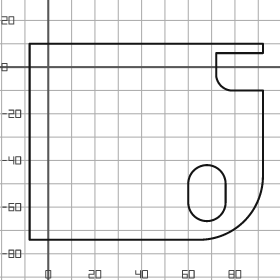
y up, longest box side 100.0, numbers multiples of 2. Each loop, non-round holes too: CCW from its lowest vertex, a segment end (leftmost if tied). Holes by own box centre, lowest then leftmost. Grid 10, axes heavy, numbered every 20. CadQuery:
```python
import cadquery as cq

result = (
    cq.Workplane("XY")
    .moveTo(-8.0, -74.0)
    .lineTo(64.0, -74.0)
    .threePointArc((84.0, -66.0), (92.0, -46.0))
    .lineTo(92.0, -10.0)
    .lineTo(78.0, -10.0)
    .threePointArc((74.0, -8.0), (72.0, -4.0))
    .lineTo(72.0, 6.0)
    .lineTo(92.0, 6.0)
    .lineTo(92.0, 10.0)
    .lineTo(-8.0, 10.0)
    .close()
    .moveTo(60.0, -58.0)
    .threePointArc((68.0, -66.0), (76.0, -58.0))
    .lineTo(76.0, -50.0)
    .threePointArc((68.0, -42.0), (60.0, -50.0))
    .close()
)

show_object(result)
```